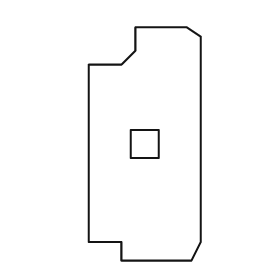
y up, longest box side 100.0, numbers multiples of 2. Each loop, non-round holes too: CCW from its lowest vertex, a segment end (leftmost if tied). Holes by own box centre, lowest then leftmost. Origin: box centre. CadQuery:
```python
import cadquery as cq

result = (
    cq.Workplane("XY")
    .moveTo(-10.0, -50.0)
    .lineTo(20.0, -50.0)
    .lineTo(24.0, -42.0)
    .lineTo(24.0, 46.0)
    .lineTo(18.0, 50.0)
    .lineTo(-4.0, 50.0)
    .lineTo(-4.0, 40.0)
    .lineTo(-10.0, 34.0)
    .lineTo(-24.0, 34.0)
    .lineTo(-24.0, -42.0)
    .lineTo(-10.0, -42.0)
    .close()
    .moveTo(-6.0, -6.0)
    .lineTo(6.0, -6.0)
    .lineTo(6.0, 6.0)
    .lineTo(-6.0, 6.0)
    .close()
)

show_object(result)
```